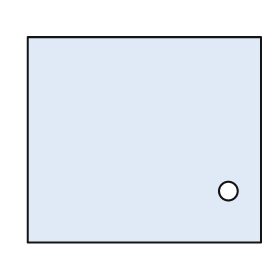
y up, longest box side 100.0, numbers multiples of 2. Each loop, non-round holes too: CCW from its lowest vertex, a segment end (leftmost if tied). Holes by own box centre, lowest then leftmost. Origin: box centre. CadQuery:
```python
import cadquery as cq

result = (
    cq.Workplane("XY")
    .moveTo(-50.0, -44.0)
    .lineTo(50.0, -44.0)
    .lineTo(50.0, 44.0)
    .lineTo(-50.0, 44.0)
    .close()
    .moveTo(36.0, -22.0)
    .circle(4.0)
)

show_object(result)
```